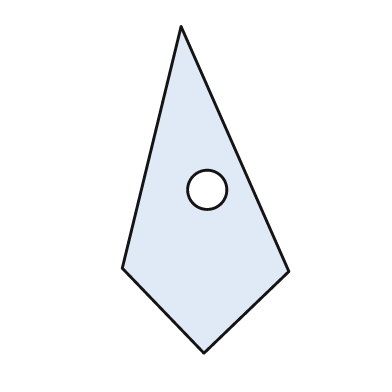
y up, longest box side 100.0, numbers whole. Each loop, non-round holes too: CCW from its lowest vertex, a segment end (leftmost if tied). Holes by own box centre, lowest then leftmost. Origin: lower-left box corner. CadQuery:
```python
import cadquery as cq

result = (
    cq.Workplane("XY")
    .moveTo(25.0, 0.0)
    .lineTo(51.0, 25.0)
    .lineTo(18.0, 100.0)
    .lineTo(0.0, 26.0)
    .close()
    .moveTo(26.0, 50.0)
    .circle(6.0)
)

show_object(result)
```